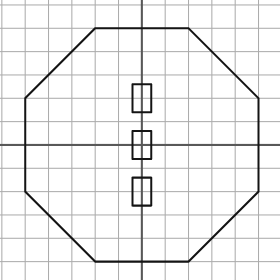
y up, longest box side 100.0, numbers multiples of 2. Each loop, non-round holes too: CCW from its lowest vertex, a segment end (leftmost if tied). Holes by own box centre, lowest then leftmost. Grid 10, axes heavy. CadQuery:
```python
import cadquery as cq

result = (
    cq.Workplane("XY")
    .moveTo(-20.0, -50.0)
    .lineTo(20.0, -50.0)
    .lineTo(50.0, -20.0)
    .lineTo(50.0, 20.0)
    .lineTo(20.0, 50.0)
    .lineTo(-20.0, 50.0)
    .lineTo(-50.0, 20.0)
    .lineTo(-50.0, -20.0)
    .close()
    .moveTo(-4.0, -26.0)
    .lineTo(4.0, -26.0)
    .lineTo(4.0, -14.0)
    .lineTo(-4.0, -14.0)
    .close()
    .moveTo(-4.0, -6.0)
    .lineTo(4.0, -6.0)
    .lineTo(4.0, 6.0)
    .lineTo(-4.0, 6.0)
    .close()
    .moveTo(-4.0, 14.0)
    .lineTo(4.0, 14.0)
    .lineTo(4.0, 26.0)
    .lineTo(-4.0, 26.0)
    .close()
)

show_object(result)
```